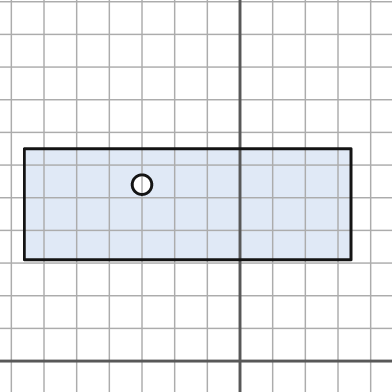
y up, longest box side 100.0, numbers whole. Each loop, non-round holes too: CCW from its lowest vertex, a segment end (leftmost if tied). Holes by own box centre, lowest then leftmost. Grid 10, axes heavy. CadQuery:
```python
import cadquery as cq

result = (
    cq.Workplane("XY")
    .moveTo(-66.0, 31.0)
    .lineTo(34.0, 31.0)
    .lineTo(34.0, 65.0)
    .lineTo(-66.0, 65.0)
    .close()
    .moveTo(-30.0, 54.0)
    .circle(3.0)
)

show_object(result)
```